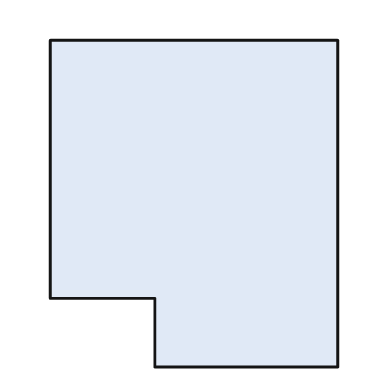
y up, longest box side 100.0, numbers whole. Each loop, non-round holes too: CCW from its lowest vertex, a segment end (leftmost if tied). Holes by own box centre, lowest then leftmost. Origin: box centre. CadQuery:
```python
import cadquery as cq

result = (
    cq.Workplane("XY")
    .moveTo(-12.0, -50.0)
    .lineTo(44.0, -50.0)
    .lineTo(44.0, 50.0)
    .lineTo(-44.0, 50.0)
    .lineTo(-44.0, -29.0)
    .lineTo(-12.0, -29.0)
    .close()
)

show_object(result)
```